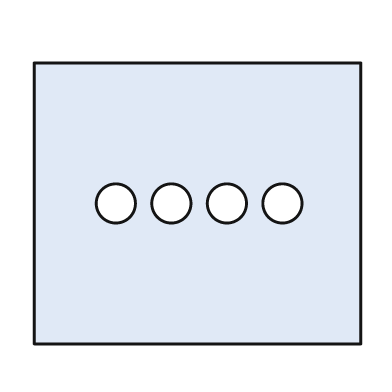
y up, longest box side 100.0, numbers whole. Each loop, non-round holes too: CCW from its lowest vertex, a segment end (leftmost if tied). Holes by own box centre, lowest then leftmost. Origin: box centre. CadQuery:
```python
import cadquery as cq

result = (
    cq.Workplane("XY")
    .moveTo(-50.0, -43.0)
    .lineTo(50.0, -43.0)
    .lineTo(50.0, 43.0)
    .lineTo(-50.0, 43.0)
    .close()
    .moveTo(-25.0, 0.0)
    .circle(6.0)
    .moveTo(-8.0, 0.0)
    .circle(6.0)
    .moveTo(9.0, 0.0)
    .circle(6.0)
    .moveTo(26.0, 0.0)
    .circle(6.0)
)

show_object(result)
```